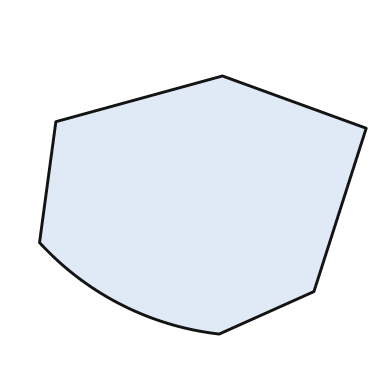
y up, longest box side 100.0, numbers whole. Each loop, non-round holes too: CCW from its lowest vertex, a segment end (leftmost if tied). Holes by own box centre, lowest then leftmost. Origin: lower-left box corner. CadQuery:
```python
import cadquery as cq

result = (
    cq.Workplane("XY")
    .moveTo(55.0, 0.0)
    .lineTo(84.0, 13.0)
    .lineTo(100.0, 63.0)
    .lineTo(56.0, 79.0)
    .lineTo(5.0, 65.0)
    .lineTo(0.0, 28.0)
    .threePointArc((25.0, 9.0), (55.0, 0.0))
    .close()
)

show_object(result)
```